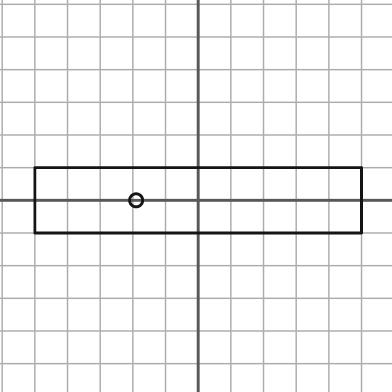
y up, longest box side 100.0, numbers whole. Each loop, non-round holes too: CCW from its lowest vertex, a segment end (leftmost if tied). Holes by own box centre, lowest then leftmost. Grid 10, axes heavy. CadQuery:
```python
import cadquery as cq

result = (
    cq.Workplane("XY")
    .moveTo(-50.0, -10.0)
    .lineTo(50.0, -10.0)
    .lineTo(50.0, 10.0)
    .lineTo(-50.0, 10.0)
    .close()
    .moveTo(-19.0, 0.0)
    .circle(2.0)
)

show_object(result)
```